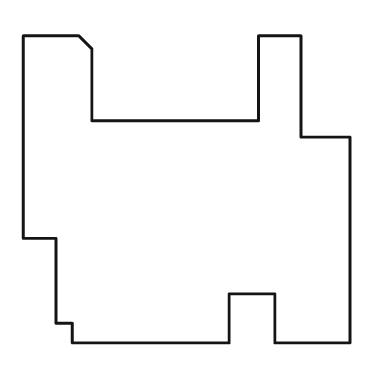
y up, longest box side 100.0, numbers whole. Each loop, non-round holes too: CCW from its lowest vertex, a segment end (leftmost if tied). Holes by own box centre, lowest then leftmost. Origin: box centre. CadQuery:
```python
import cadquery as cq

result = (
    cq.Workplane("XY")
    .moveTo(-35.0, -47.0)
    .lineTo(13.0, -47.0)
    .lineTo(13.0, -32.0)
    .lineTo(27.0, -32.0)
    .lineTo(27.0, -47.0)
    .lineTo(50.0, -47.0)
    .lineTo(50.0, 16.0)
    .lineTo(35.0, 16.0)
    .lineTo(35.0, 47.0)
    .lineTo(22.0, 47.0)
    .lineTo(22.0, 21.0)
    .lineTo(-29.0, 21.0)
    .lineTo(-29.0, 43.0)
    .lineTo(-33.0, 47.0)
    .lineTo(-50.0, 47.0)
    .lineTo(-50.0, -15.0)
    .lineTo(-40.0, -15.0)
    .lineTo(-40.0, -41.0)
    .lineTo(-35.0, -41.0)
    .close()
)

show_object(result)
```